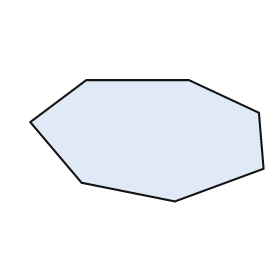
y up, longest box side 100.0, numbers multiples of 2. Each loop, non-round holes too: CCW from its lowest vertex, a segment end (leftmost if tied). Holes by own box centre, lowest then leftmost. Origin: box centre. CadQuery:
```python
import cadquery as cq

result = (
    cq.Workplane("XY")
    .moveTo(12.0, -26.0)
    .lineTo(50.0, -12.0)
    .lineTo(48.0, 12.0)
    .lineTo(18.0, 26.0)
    .lineTo(-26.0, 26.0)
    .lineTo(-50.0, 8.0)
    .lineTo(-28.0, -18.0)
    .close()
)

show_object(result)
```